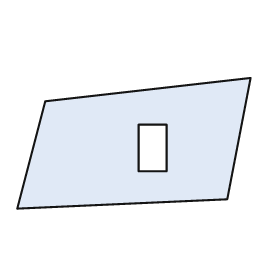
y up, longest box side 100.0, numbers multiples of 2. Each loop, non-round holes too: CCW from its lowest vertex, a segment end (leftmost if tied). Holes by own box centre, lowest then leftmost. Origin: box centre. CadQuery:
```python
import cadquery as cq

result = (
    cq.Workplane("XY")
    .moveTo(-50.0, -28.0)
    .lineTo(40.0, -24.0)
    .lineTo(50.0, 28.0)
    .lineTo(-38.0, 18.0)
    .close()
    .moveTo(2.0, -12.0)
    .lineTo(14.0, -12.0)
    .lineTo(14.0, 8.0)
    .lineTo(2.0, 8.0)
    .close()
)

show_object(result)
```